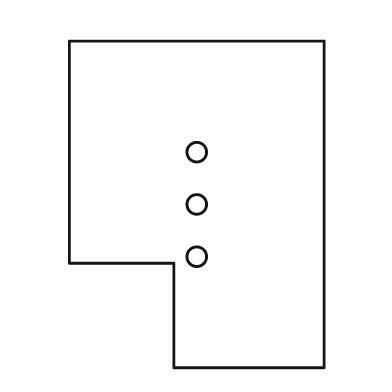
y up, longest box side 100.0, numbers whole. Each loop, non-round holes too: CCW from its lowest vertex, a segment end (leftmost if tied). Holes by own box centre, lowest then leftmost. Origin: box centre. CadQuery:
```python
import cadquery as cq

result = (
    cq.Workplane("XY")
    .moveTo(-7.0, -50.0)
    .lineTo(39.0, -50.0)
    .lineTo(39.0, 50.0)
    .lineTo(-39.0, 50.0)
    .lineTo(-39.0, -18.0)
    .lineTo(-7.0, -18.0)
    .close()
    .moveTo(0.0, -16.0)
    .circle(3.0)
    .moveTo(0.0, 0.0)
    .circle(3.0)
    .moveTo(0.0, 16.0)
    .circle(3.0)
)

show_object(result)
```